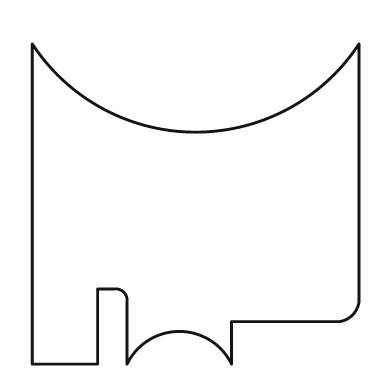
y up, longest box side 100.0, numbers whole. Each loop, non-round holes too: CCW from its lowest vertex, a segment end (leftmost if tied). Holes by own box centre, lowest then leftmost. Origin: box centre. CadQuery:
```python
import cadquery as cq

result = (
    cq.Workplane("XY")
    .moveTo(-50.0, -49.0)
    .lineTo(-30.0, -49.0)
    .lineTo(-30.0, -26.0)
    .lineTo(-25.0, -26.0)
    .threePointArc((-22.0, -27.0), (-21.0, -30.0))
    .lineTo(-21.0, -49.0)
    .threePointArc((-5.0, -39.0), (11.0, -49.0))
    .lineTo(11.0, -36.0)
    .lineTo(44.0, -36.0)
    .threePointArc((48.0, -34.0), (50.0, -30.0))
    .lineTo(50.0, 49.0)
    .threePointArc((0.0, 22.0), (-50.0, 49.0))
    .close()
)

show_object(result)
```